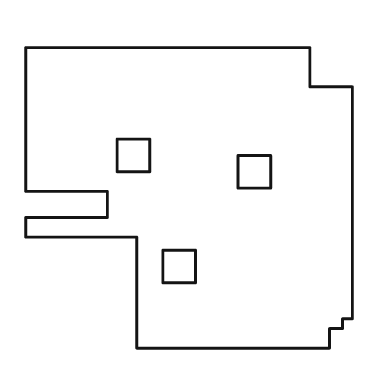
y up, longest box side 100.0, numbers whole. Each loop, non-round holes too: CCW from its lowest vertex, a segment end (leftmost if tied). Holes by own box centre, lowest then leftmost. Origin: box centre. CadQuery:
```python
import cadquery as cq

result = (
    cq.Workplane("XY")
    .moveTo(-16.0, -46.0)
    .lineTo(43.0, -46.0)
    .lineTo(43.0, -40.0)
    .lineTo(47.0, -40.0)
    .lineTo(47.0, -37.0)
    .lineTo(50.0, -37.0)
    .lineTo(50.0, 34.0)
    .lineTo(37.0, 34.0)
    .lineTo(37.0, 46.0)
    .lineTo(-50.0, 46.0)
    .lineTo(-50.0, 2.0)
    .lineTo(-25.0, 2.0)
    .lineTo(-25.0, -6.0)
    .lineTo(-50.0, -6.0)
    .lineTo(-50.0, -12.0)
    .lineTo(-16.0, -12.0)
    .close()
    .moveTo(-8.0, -26.0)
    .lineTo(2.0, -26.0)
    .lineTo(2.0, -16.0)
    .lineTo(-8.0, -16.0)
    .close()
    .moveTo(15.0, 3.0)
    .lineTo(25.0, 3.0)
    .lineTo(25.0, 13.0)
    .lineTo(15.0, 13.0)
    .close()
    .moveTo(-22.0, 8.0)
    .lineTo(-12.0, 8.0)
    .lineTo(-12.0, 18.0)
    .lineTo(-22.0, 18.0)
    .close()
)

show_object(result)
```